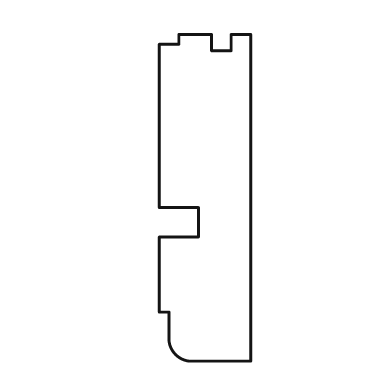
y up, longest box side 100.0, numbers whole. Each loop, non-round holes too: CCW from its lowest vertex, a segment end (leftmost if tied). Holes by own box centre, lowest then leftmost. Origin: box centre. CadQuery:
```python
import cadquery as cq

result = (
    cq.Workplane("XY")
    .moveTo(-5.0, -50.0)
    .lineTo(14.0, -50.0)
    .lineTo(14.0, 50.0)
    .lineTo(8.0, 50.0)
    .lineTo(8.0, 45.0)
    .lineTo(2.0, 45.0)
    .lineTo(2.0, 50.0)
    .lineTo(-8.0, 50.0)
    .lineTo(-8.0, 47.0)
    .lineTo(-14.0, 47.0)
    .lineTo(-14.0, -3.0)
    .lineTo(-2.0, -3.0)
    .lineTo(-2.0, -12.0)
    .lineTo(-14.0, -12.0)
    .lineTo(-14.0, -35.0)
    .lineTo(-11.0, -35.0)
    .lineTo(-11.0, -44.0)
    .threePointArc((-9.0, -48.0), (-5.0, -50.0))
    .close()
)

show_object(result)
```